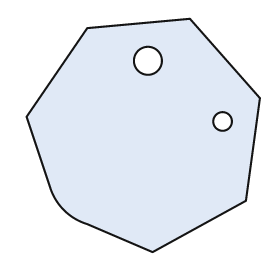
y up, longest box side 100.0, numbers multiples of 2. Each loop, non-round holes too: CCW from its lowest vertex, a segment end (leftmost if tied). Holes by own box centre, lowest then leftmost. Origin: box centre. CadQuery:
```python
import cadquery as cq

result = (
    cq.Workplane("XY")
    .moveTo(4.0, -50.0)
    .lineTo(44.0, -28.0)
    .lineTo(50.0, 16.0)
    .lineTo(20.0, 50.0)
    .lineTo(-24.0, 46.0)
    .lineTo(-50.0, 8.0)
    .lineTo(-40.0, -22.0)
    .threePointArc((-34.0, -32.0), (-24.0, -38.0))
    .close()
    .moveTo(34.0, 6.0)
    .circle(4.0)
    .moveTo(2.0, 32.0)
    .circle(6.0)
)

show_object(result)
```